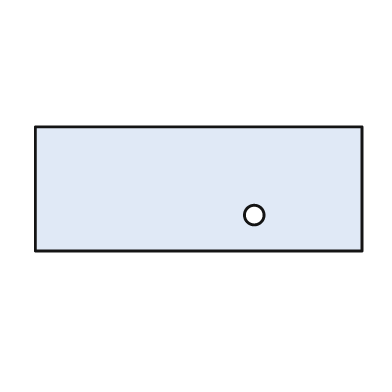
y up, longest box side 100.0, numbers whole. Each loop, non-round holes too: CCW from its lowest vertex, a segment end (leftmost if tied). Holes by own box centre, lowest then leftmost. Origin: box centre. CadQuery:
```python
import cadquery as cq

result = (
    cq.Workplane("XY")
    .moveTo(-50.0, -19.0)
    .lineTo(50.0, -19.0)
    .lineTo(50.0, 19.0)
    .lineTo(-50.0, 19.0)
    .close()
    .moveTo(17.0, -8.0)
    .circle(3.0)
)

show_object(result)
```